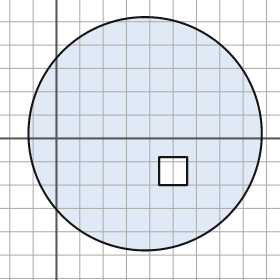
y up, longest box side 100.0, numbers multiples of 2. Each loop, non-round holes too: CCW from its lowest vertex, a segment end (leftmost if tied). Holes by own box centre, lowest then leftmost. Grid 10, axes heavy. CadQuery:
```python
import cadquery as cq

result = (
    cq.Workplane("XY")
    .moveTo(38.0, 2.0)
    .circle(50.0)
    .moveTo(44.0, -20.0)
    .lineTo(56.0, -20.0)
    .lineTo(56.0, -8.0)
    .lineTo(44.0, -8.0)
    .close()
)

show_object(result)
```